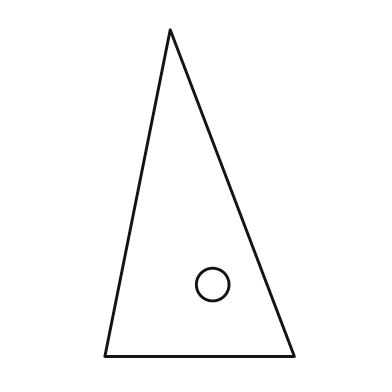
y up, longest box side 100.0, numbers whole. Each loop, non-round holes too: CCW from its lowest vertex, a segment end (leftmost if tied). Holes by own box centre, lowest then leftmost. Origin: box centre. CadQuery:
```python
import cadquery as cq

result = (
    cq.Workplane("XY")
    .moveTo(-29.0, -50.0)
    .lineTo(29.0, -50.0)
    .lineTo(-9.0, 50.0)
    .close()
    .moveTo(4.0, -28.0)
    .circle(5.0)
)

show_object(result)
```